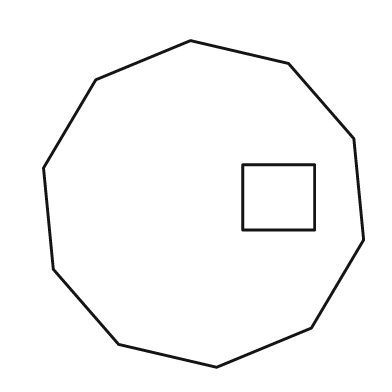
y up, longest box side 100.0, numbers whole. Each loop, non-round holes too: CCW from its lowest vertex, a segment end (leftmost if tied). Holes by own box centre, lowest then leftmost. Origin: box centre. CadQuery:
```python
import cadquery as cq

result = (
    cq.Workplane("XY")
    .moveTo(4.0, -50.0)
    .lineTo(33.0, -38.0)
    .lineTo(49.0, -11.0)
    .lineTo(46.0, 20.0)
    .lineTo(26.0, 43.0)
    .lineTo(-4.0, 50.0)
    .lineTo(-33.0, 38.0)
    .lineTo(-49.0, 11.0)
    .lineTo(-46.0, -20.0)
    .lineTo(-26.0, -43.0)
    .close()
    .moveTo(12.0, -8.0)
    .lineTo(34.0, -8.0)
    .lineTo(34.0, 12.0)
    .lineTo(12.0, 12.0)
    .close()
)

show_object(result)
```